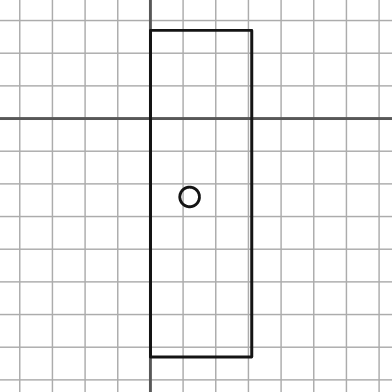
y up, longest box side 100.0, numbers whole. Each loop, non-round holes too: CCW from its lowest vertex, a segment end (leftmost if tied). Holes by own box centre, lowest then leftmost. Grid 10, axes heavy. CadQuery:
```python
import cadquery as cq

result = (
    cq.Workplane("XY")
    .moveTo(0.0, -73.0)
    .lineTo(31.0, -73.0)
    .lineTo(31.0, 27.0)
    .lineTo(0.0, 27.0)
    .close()
    .moveTo(12.0, -24.0)
    .circle(3.0)
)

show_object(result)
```